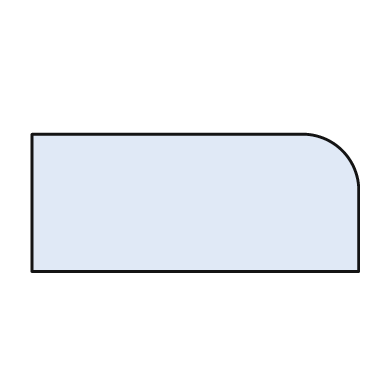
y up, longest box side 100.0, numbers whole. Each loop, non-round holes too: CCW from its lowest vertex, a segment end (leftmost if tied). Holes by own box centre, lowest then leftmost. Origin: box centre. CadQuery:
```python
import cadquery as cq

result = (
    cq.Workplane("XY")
    .moveTo(-50.0, -21.0)
    .lineTo(50.0, -21.0)
    .lineTo(50.0, 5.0)
    .threePointArc((45.0, 16.0), (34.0, 21.0))
    .lineTo(-50.0, 21.0)
    .close()
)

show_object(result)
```